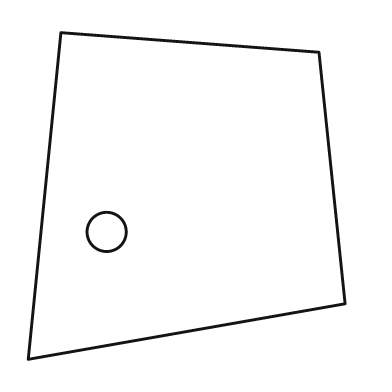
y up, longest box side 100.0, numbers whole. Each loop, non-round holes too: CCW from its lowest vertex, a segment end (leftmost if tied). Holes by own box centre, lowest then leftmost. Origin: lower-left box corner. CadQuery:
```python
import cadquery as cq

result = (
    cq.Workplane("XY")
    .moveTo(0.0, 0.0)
    .lineTo(97.0, 17.0)
    .lineTo(89.0, 94.0)
    .lineTo(10.0, 100.0)
    .close()
    .moveTo(24.0, 39.0)
    .circle(6.0)
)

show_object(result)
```